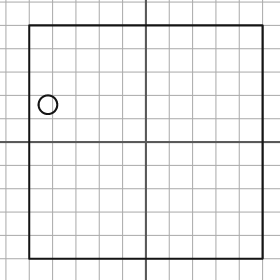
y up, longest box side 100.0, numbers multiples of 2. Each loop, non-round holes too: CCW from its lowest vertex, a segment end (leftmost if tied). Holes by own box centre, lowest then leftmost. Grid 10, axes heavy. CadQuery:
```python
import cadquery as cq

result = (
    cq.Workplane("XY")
    .moveTo(-50.0, -50.0)
    .lineTo(50.0, -50.0)
    .lineTo(50.0, 50.0)
    .lineTo(-50.0, 50.0)
    .close()
    .moveTo(-42.0, 16.0)
    .circle(4.0)
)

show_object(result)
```